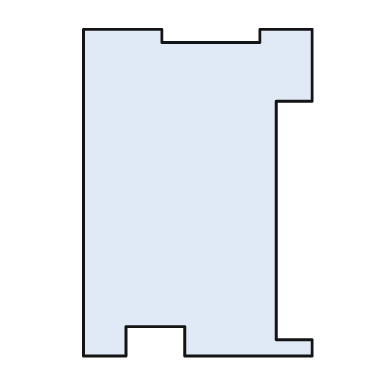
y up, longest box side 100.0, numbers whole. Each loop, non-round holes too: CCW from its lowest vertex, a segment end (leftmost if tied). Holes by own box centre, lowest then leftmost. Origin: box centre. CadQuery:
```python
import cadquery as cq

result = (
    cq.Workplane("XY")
    .moveTo(-35.0, -50.0)
    .lineTo(-22.0, -50.0)
    .lineTo(-22.0, -41.0)
    .lineTo(-4.0, -41.0)
    .lineTo(-4.0, -50.0)
    .lineTo(35.0, -50.0)
    .lineTo(35.0, -45.0)
    .lineTo(24.0, -45.0)
    .lineTo(24.0, 28.0)
    .lineTo(35.0, 28.0)
    .lineTo(35.0, 50.0)
    .lineTo(19.0, 50.0)
    .lineTo(19.0, 46.0)
    .lineTo(-11.0, 46.0)
    .lineTo(-11.0, 50.0)
    .lineTo(-35.0, 50.0)
    .close()
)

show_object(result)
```